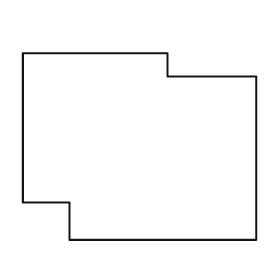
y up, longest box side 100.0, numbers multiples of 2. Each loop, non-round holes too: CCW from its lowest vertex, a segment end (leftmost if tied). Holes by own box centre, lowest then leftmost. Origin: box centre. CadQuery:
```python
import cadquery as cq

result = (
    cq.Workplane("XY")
    .moveTo(-30.0, -40.0)
    .lineTo(50.0, -40.0)
    .lineTo(50.0, 30.0)
    .lineTo(12.0, 30.0)
    .lineTo(12.0, 40.0)
    .lineTo(-50.0, 40.0)
    .lineTo(-50.0, -24.0)
    .lineTo(-30.0, -24.0)
    .close()
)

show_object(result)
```